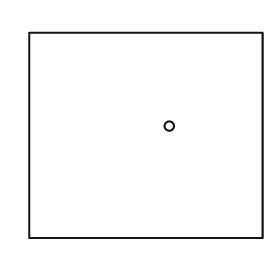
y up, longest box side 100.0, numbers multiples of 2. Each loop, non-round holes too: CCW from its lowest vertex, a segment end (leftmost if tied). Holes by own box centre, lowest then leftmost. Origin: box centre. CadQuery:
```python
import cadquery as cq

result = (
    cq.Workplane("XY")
    .moveTo(-50.0, -44.0)
    .lineTo(50.0, -44.0)
    .lineTo(50.0, 44.0)
    .lineTo(-50.0, 44.0)
    .close()
    .moveTo(10.0, 4.0)
    .circle(2.0)
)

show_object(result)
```